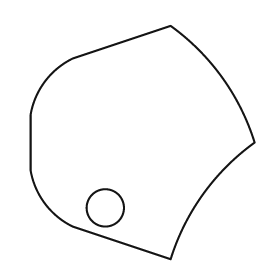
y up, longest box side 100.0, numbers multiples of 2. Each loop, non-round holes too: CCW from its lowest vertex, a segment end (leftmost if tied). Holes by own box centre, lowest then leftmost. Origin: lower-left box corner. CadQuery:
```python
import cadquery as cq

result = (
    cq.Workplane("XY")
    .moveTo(60.0, 0.0)
    .threePointArc((74.0, 28.0), (96.0, 50.0))
    .threePointArc((82.0, 78.0), (60.0, 100.0))
    .lineTo(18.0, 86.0)
    .threePointArc((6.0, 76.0), (0.0, 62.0))
    .lineTo(0.0, 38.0)
    .threePointArc((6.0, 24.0), (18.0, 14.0))
    .close()
    .moveTo(32.0, 22.0)
    .circle(8.0)
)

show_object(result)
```